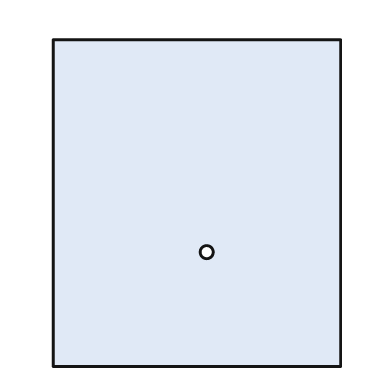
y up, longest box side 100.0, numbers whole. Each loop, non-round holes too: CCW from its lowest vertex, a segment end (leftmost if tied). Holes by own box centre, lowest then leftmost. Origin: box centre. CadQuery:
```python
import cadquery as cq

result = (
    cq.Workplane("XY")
    .moveTo(-44.0, -50.0)
    .lineTo(44.0, -50.0)
    .lineTo(44.0, 50.0)
    .lineTo(-44.0, 50.0)
    .close()
    .moveTo(3.0, -15.0)
    .circle(2.0)
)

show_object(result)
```